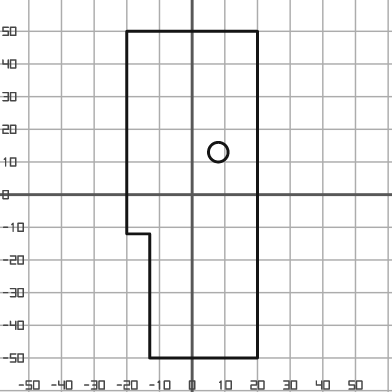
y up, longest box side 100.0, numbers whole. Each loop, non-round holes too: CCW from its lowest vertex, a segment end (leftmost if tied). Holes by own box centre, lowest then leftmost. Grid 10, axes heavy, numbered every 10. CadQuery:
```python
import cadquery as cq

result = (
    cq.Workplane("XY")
    .moveTo(-13.0, -50.0)
    .lineTo(20.0, -50.0)
    .lineTo(20.0, 50.0)
    .lineTo(-20.0, 50.0)
    .lineTo(-20.0, -12.0)
    .lineTo(-13.0, -12.0)
    .close()
    .moveTo(8.0, 13.0)
    .circle(3.0)
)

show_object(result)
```